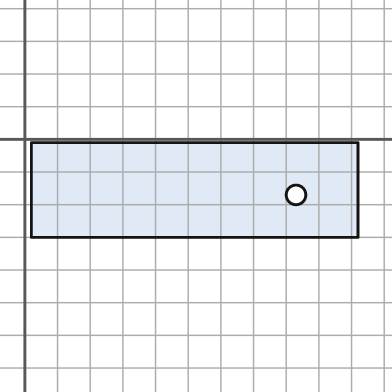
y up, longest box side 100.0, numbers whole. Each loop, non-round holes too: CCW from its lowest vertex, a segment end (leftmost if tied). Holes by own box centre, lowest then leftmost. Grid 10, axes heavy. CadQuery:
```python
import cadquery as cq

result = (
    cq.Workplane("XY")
    .moveTo(2.0, -30.0)
    .lineTo(102.0, -30.0)
    .lineTo(102.0, -1.0)
    .lineTo(2.0, -1.0)
    .close()
    .moveTo(83.0, -17.0)
    .circle(3.0)
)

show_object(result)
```